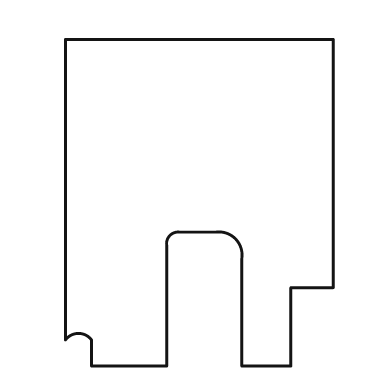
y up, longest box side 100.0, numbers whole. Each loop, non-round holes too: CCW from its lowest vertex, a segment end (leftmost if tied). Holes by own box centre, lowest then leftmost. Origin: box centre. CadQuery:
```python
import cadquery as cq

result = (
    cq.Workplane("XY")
    .moveTo(-33.0, -50.0)
    .lineTo(-10.0, -50.0)
    .lineTo(-10.0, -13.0)
    .threePointArc((-9.0, -10.0), (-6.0, -9.0))
    .lineTo(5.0, -9.0)
    .threePointArc((11.0, -11.0), (13.0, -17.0))
    .lineTo(13.0, -50.0)
    .lineTo(28.0, -50.0)
    .lineTo(28.0, -26.0)
    .lineTo(41.0, -26.0)
    .lineTo(41.0, 50.0)
    .lineTo(-41.0, 50.0)
    .lineTo(-41.0, -42.0)
    .threePointArc((-37.0, -40.0), (-33.0, -42.0))
    .close()
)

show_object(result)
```